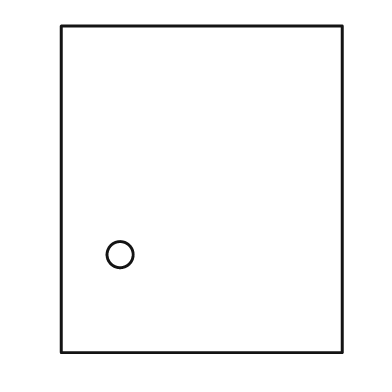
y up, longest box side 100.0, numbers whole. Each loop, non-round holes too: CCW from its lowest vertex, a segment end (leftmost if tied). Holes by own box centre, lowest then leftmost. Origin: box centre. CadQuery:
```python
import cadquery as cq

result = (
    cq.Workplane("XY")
    .moveTo(-43.0, -50.0)
    .lineTo(43.0, -50.0)
    .lineTo(43.0, 50.0)
    .lineTo(-43.0, 50.0)
    .close()
    .moveTo(-25.0, -20.0)
    .circle(4.0)
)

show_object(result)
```